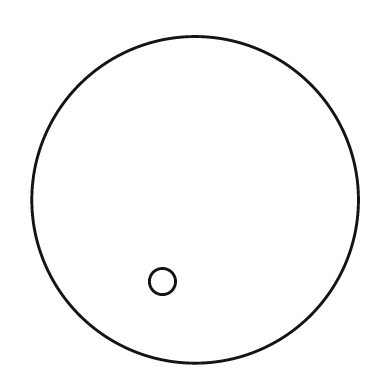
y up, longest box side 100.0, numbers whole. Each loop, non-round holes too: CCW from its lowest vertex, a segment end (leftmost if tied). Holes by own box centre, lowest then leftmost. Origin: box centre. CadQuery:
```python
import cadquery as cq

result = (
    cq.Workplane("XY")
    .moveTo(0.0, 0.0)
    .circle(50.0)
    .moveTo(-10.0, -25.0)
    .circle(4.0)
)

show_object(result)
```